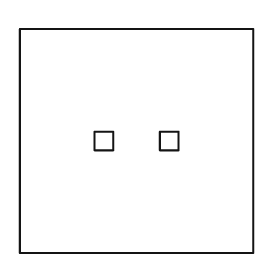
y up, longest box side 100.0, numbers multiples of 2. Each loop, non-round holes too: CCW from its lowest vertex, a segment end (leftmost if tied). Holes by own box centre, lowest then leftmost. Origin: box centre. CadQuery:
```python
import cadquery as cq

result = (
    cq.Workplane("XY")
    .moveTo(-50.0, -48.0)
    .lineTo(50.0, -48.0)
    .lineTo(50.0, 48.0)
    .lineTo(-50.0, 48.0)
    .close()
    .moveTo(-18.0, -4.0)
    .lineTo(-10.0, -4.0)
    .lineTo(-10.0, 4.0)
    .lineTo(-18.0, 4.0)
    .close()
    .moveTo(10.0, -4.0)
    .lineTo(18.0, -4.0)
    .lineTo(18.0, 4.0)
    .lineTo(10.0, 4.0)
    .close()
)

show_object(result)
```